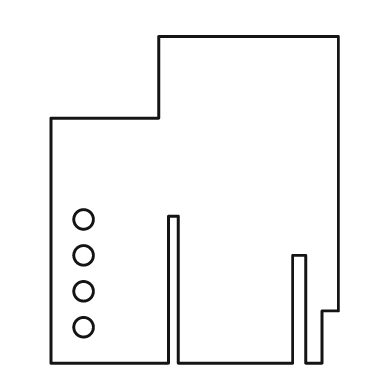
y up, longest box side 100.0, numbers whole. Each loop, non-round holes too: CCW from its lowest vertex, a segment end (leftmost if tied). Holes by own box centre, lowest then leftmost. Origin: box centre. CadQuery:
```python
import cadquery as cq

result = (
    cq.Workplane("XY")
    .moveTo(-44.0, -50.0)
    .lineTo(-8.0, -50.0)
    .lineTo(-8.0, -5.0)
    .lineTo(-5.0, -5.0)
    .lineTo(-5.0, -50.0)
    .lineTo(30.0, -50.0)
    .lineTo(30.0, -17.0)
    .lineTo(34.0, -17.0)
    .lineTo(34.0, -50.0)
    .lineTo(39.0, -50.0)
    .lineTo(39.0, -34.0)
    .lineTo(44.0, -34.0)
    .lineTo(44.0, 50.0)
    .lineTo(-11.0, 50.0)
    .lineTo(-11.0, 25.0)
    .lineTo(-44.0, 25.0)
    .close()
    .moveTo(-34.0, -39.0)
    .circle(3.0)
    .moveTo(-34.0, -28.0)
    .circle(3.0)
    .moveTo(-34.0, -17.0)
    .circle(3.0)
    .moveTo(-34.0, -6.0)
    .circle(3.0)
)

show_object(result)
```